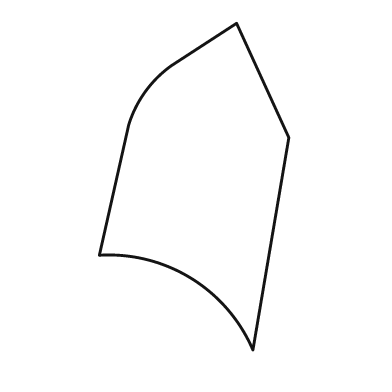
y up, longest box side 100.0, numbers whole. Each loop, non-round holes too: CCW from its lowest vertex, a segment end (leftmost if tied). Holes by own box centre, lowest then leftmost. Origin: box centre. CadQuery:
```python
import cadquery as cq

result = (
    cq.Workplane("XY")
    .moveTo(18.0, -50.0)
    .lineTo(29.0, 15.0)
    .lineTo(13.0, 50.0)
    .lineTo(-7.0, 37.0)
    .threePointArc((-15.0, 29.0), (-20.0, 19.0))
    .lineTo(-29.0, -21.0)
    .threePointArc((-1.0, -28.0), (18.0, -50.0))
    .close()
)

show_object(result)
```